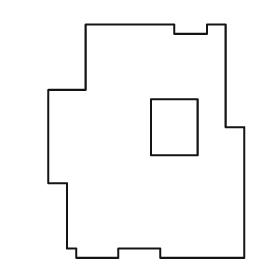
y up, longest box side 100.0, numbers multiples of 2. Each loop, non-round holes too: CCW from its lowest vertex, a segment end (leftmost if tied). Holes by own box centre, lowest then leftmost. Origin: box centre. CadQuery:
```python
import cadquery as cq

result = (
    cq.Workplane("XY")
    .moveTo(-30.0, -50.0)
    .lineTo(-12.0, -50.0)
    .lineTo(-12.0, -46.0)
    .lineTo(6.0, -46.0)
    .lineTo(6.0, -50.0)
    .lineTo(42.0, -50.0)
    .lineTo(42.0, 6.0)
    .lineTo(34.0, 6.0)
    .lineTo(34.0, 50.0)
    .lineTo(26.0, 50.0)
    .lineTo(26.0, 46.0)
    .lineTo(12.0, 46.0)
    .lineTo(12.0, 50.0)
    .lineTo(-26.0, 50.0)
    .lineTo(-26.0, 22.0)
    .lineTo(-42.0, 22.0)
    .lineTo(-42.0, -18.0)
    .lineTo(-34.0, -18.0)
    .lineTo(-34.0, -46.0)
    .lineTo(-30.0, -46.0)
    .close()
    .moveTo(2.0, -6.0)
    .lineTo(22.0, -6.0)
    .lineTo(22.0, 18.0)
    .lineTo(2.0, 18.0)
    .close()
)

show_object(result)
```